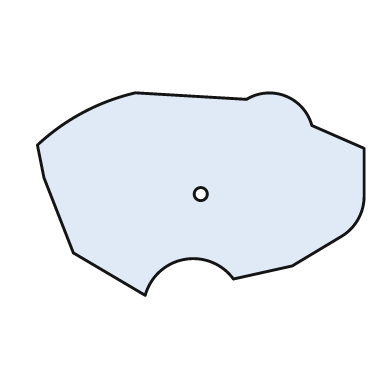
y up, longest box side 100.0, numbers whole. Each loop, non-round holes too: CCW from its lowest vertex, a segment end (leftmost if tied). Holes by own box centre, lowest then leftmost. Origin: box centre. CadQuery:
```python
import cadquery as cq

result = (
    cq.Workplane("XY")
    .moveTo(-17.0, -31.0)
    .threePointArc((-5.0, -20.0), (10.0, -26.0))
    .lineTo(28.0, -22.0)
    .lineTo(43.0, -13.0)
    .threePointArc((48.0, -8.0), (50.0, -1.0))
    .lineTo(50.0, 14.0)
    .lineTo(34.0, 21.0)
    .threePointArc((26.0, 30.0), (14.0, 29.0))
    .lineTo(-20.0, 31.0)
    .threePointArc((-36.0, 25.0), (-50.0, 15.0))
    .lineTo(-48.0, 5.0)
    .lineTo(-39.0, -18.0)
    .close()
    .moveTo(0.0, 0.0)
    .circle(2.0)
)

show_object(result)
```